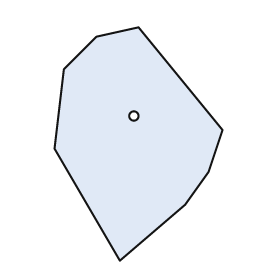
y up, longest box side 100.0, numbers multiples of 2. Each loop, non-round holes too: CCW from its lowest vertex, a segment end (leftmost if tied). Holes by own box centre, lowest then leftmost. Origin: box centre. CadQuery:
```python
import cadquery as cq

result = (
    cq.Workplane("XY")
    .moveTo(-8.0, -50.0)
    .lineTo(20.0, -26.0)
    .lineTo(30.0, -12.0)
    .lineTo(36.0, 6.0)
    .lineTo(0.0, 50.0)
    .lineTo(-18.0, 46.0)
    .lineTo(-32.0, 32.0)
    .lineTo(-36.0, -2.0)
    .close()
    .moveTo(-2.0, 12.0)
    .circle(2.0)
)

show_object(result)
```